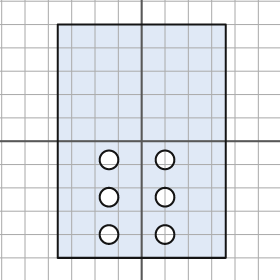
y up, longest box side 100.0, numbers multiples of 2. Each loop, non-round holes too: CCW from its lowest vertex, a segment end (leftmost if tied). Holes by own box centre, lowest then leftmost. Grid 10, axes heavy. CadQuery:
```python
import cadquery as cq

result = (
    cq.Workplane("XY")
    .moveTo(-36.0, -50.0)
    .lineTo(36.0, -50.0)
    .lineTo(36.0, 50.0)
    .lineTo(-36.0, 50.0)
    .close()
    .moveTo(-14.0, -40.0)
    .circle(4.0)
    .moveTo(10.0, -40.0)
    .circle(4.0)
    .moveTo(-14.0, -24.0)
    .circle(4.0)
    .moveTo(10.0, -24.0)
    .circle(4.0)
    .moveTo(-14.0, -8.0)
    .circle(4.0)
    .moveTo(10.0, -8.0)
    .circle(4.0)
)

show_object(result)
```